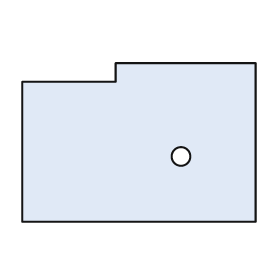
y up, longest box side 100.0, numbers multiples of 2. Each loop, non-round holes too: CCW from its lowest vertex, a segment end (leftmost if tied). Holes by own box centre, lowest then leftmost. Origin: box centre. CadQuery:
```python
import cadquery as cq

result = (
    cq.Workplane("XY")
    .moveTo(-50.0, -34.0)
    .lineTo(50.0, -34.0)
    .lineTo(50.0, 34.0)
    .lineTo(-10.0, 34.0)
    .lineTo(-10.0, 26.0)
    .lineTo(-50.0, 26.0)
    .close()
    .moveTo(18.0, -6.0)
    .circle(4.0)
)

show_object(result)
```